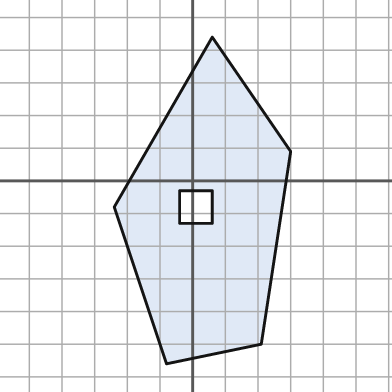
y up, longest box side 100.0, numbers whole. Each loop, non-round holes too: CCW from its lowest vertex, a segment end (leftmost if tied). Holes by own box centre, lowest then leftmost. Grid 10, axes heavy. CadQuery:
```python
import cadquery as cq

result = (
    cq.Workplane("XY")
    .moveTo(-8.0, -56.0)
    .lineTo(21.0, -50.0)
    .lineTo(30.0, 9.0)
    .lineTo(6.0, 44.0)
    .lineTo(-24.0, -8.0)
    .close()
    .moveTo(-4.0, -13.0)
    .lineTo(6.0, -13.0)
    .lineTo(6.0, -3.0)
    .lineTo(-4.0, -3.0)
    .close()
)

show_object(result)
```